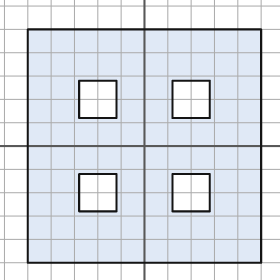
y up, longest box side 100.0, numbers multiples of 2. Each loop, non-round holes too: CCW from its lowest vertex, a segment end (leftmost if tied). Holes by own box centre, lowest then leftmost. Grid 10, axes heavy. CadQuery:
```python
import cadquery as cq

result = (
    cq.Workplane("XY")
    .moveTo(-50.0, -50.0)
    .lineTo(50.0, -50.0)
    .lineTo(50.0, 50.0)
    .lineTo(-50.0, 50.0)
    .close()
    .moveTo(-28.0, -28.0)
    .lineTo(-12.0, -28.0)
    .lineTo(-12.0, -12.0)
    .lineTo(-28.0, -12.0)
    .close()
    .moveTo(12.0, -28.0)
    .lineTo(28.0, -28.0)
    .lineTo(28.0, -12.0)
    .lineTo(12.0, -12.0)
    .close()
    .moveTo(-28.0, 12.0)
    .lineTo(-12.0, 12.0)
    .lineTo(-12.0, 28.0)
    .lineTo(-28.0, 28.0)
    .close()
    .moveTo(12.0, 12.0)
    .lineTo(28.0, 12.0)
    .lineTo(28.0, 28.0)
    .lineTo(12.0, 28.0)
    .close()
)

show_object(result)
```